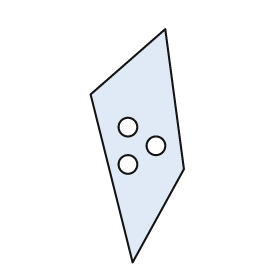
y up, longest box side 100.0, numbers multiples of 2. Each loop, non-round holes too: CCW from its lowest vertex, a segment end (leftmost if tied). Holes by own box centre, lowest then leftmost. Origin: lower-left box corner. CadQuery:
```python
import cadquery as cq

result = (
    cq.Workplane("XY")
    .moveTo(18.0, 0.0)
    .lineTo(40.0, 40.0)
    .lineTo(32.0, 100.0)
    .lineTo(0.0, 72.0)
    .close()
    .moveTo(16.0, 42.0)
    .circle(4.0)
    .moveTo(28.0, 50.0)
    .circle(4.0)
    .moveTo(16.0, 58.0)
    .circle(4.0)
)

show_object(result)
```